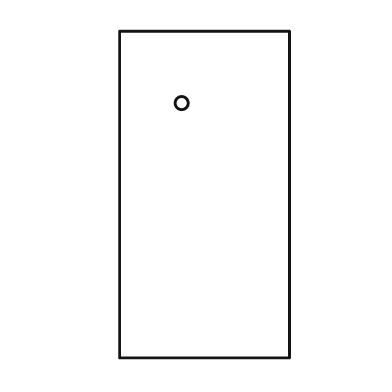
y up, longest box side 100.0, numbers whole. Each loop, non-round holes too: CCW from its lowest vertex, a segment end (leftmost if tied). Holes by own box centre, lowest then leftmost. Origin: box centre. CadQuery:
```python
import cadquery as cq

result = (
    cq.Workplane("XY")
    .moveTo(-26.0, -50.0)
    .lineTo(26.0, -50.0)
    .lineTo(26.0, 50.0)
    .lineTo(-26.0, 50.0)
    .close()
    .moveTo(-7.0, 28.0)
    .circle(2.0)
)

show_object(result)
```